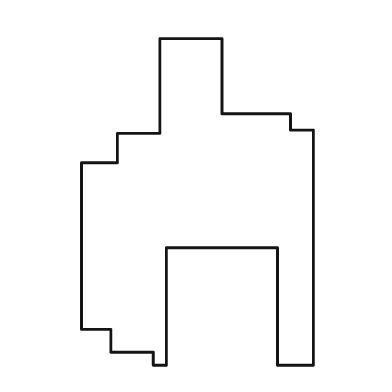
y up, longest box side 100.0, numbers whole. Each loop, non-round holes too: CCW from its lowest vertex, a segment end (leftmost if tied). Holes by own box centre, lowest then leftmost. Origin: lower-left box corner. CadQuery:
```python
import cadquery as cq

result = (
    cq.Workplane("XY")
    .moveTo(22.0, 0.0)
    .lineTo(26.0, 0.0)
    .lineTo(26.0, 36.0)
    .lineTo(60.0, 36.0)
    .lineTo(60.0, 0.0)
    .lineTo(71.0, 0.0)
    .lineTo(71.0, 72.0)
    .lineTo(64.0, 72.0)
    .lineTo(64.0, 77.0)
    .lineTo(43.0, 77.0)
    .lineTo(43.0, 100.0)
    .lineTo(24.0, 100.0)
    .lineTo(24.0, 71.0)
    .lineTo(11.0, 71.0)
    .lineTo(11.0, 62.0)
    .lineTo(0.0, 62.0)
    .lineTo(0.0, 11.0)
    .lineTo(9.0, 11.0)
    .lineTo(9.0, 4.0)
    .lineTo(22.0, 4.0)
    .close()
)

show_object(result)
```